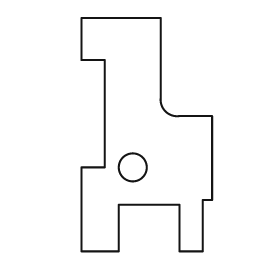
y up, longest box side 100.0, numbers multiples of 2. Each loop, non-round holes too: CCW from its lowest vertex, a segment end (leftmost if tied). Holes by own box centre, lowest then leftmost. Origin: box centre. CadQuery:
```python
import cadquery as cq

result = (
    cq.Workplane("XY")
    .moveTo(-28.0, -50.0)
    .lineTo(-12.0, -50.0)
    .lineTo(-12.0, -30.0)
    .lineTo(14.0, -30.0)
    .lineTo(14.0, -50.0)
    .lineTo(24.0, -50.0)
    .lineTo(24.0, -28.0)
    .lineTo(28.0, -28.0)
    .lineTo(28.0, 8.0)
    .lineTo(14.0, 8.0)
    .threePointArc((8.0, 10.0), (6.0, 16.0))
    .lineTo(6.0, 50.0)
    .lineTo(-28.0, 50.0)
    .lineTo(-28.0, 32.0)
    .lineTo(-18.0, 32.0)
    .lineTo(-18.0, -14.0)
    .lineTo(-28.0, -14.0)
    .close()
    .moveTo(-6.0, -14.0)
    .circle(6.0)
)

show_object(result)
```